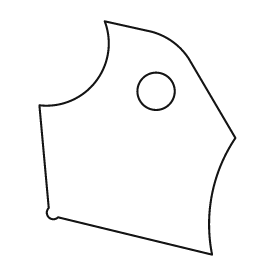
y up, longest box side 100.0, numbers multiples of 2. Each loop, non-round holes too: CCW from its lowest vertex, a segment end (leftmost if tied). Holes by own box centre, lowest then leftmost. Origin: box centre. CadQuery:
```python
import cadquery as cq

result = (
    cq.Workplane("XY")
    .moveTo(32.0, -50.0)
    .threePointArc((32.0, -24.0), (42.0, 0.0))
    .lineTo(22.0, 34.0)
    .threePointArc((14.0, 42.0), (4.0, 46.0))
    .lineTo(-14.0, 50.0)
    .threePointArc((-18.0, 24.0), (-42.0, 14.0))
    .lineTo(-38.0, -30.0)
    .threePointArc((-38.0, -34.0), (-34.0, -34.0))
    .close()
    .moveTo(8.0, 20.0)
    .circle(8.0)
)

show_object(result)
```